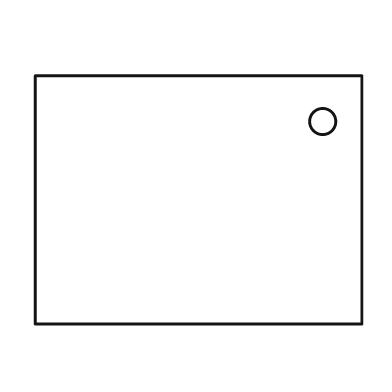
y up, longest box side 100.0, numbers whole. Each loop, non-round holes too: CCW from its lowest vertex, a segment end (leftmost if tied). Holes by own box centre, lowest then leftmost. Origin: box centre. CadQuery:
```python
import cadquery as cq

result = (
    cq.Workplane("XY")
    .moveTo(-50.0, -38.0)
    .lineTo(50.0, -38.0)
    .lineTo(50.0, 38.0)
    .lineTo(-50.0, 38.0)
    .close()
    .moveTo(38.0, 24.0)
    .circle(4.0)
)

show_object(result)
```